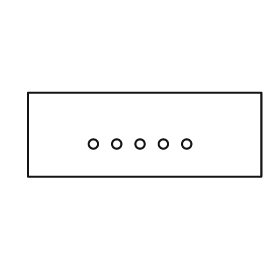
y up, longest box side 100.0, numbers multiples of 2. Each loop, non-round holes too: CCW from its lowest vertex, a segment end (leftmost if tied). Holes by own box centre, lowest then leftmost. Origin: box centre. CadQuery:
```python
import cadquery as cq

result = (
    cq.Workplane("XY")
    .moveTo(-50.0, -18.0)
    .lineTo(50.0, -18.0)
    .lineTo(50.0, 18.0)
    .lineTo(-50.0, 18.0)
    .close()
    .moveTo(-22.0, -4.0)
    .circle(2.0)
    .moveTo(-12.0, -4.0)
    .circle(2.0)
    .moveTo(-2.0, -4.0)
    .circle(2.0)
    .moveTo(8.0, -4.0)
    .circle(2.0)
    .moveTo(18.0, -4.0)
    .circle(2.0)
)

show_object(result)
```